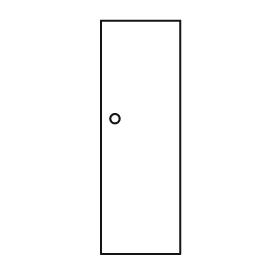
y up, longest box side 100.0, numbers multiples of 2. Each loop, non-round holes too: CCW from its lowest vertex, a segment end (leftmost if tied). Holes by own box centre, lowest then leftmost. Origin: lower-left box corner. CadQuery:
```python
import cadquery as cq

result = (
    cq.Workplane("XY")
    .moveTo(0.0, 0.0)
    .lineTo(34.0, 0.0)
    .lineTo(34.0, 100.0)
    .lineTo(0.0, 100.0)
    .close()
    .moveTo(6.0, 58.0)
    .circle(2.0)
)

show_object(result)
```